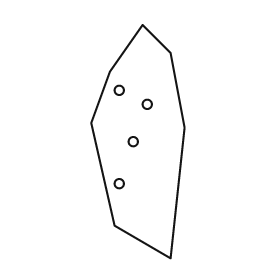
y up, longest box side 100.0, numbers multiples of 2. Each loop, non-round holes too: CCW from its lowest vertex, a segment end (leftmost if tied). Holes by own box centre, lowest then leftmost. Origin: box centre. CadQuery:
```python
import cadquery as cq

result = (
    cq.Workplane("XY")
    .moveTo(14.0, -50.0)
    .lineTo(20.0, 6.0)
    .lineTo(14.0, 38.0)
    .lineTo(2.0, 50.0)
    .lineTo(-12.0, 30.0)
    .lineTo(-20.0, 8.0)
    .lineTo(-10.0, -36.0)
    .close()
    .moveTo(-8.0, -18.0)
    .circle(2.0)
    .moveTo(-2.0, 0.0)
    .circle(2.0)
    .moveTo(4.0, 16.0)
    .circle(2.0)
    .moveTo(-8.0, 22.0)
    .circle(2.0)
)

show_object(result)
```